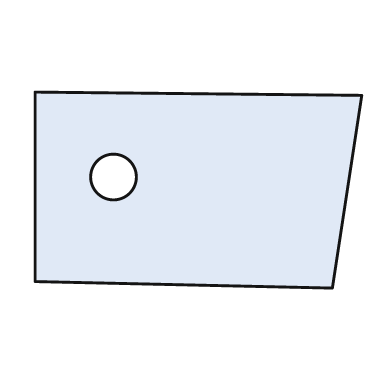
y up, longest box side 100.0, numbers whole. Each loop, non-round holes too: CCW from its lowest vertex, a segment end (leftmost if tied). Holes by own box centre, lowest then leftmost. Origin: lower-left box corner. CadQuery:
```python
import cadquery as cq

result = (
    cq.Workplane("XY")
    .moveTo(91.0, 0.0)
    .lineTo(100.0, 59.0)
    .lineTo(0.0, 60.0)
    .lineTo(0.0, 2.0)
    .close()
    .moveTo(24.0, 34.0)
    .circle(7.0)
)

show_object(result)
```